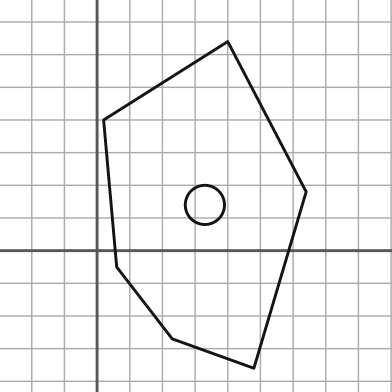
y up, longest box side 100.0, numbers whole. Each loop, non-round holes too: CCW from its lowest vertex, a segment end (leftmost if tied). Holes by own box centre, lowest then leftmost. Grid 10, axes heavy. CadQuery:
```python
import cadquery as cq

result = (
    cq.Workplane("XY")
    .moveTo(48.0, -36.0)
    .lineTo(64.0, 18.0)
    .lineTo(40.0, 64.0)
    .lineTo(2.0, 40.0)
    .lineTo(6.0, -5.0)
    .lineTo(23.0, -27.0)
    .close()
    .moveTo(33.0, 14.0)
    .circle(6.0)
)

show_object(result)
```